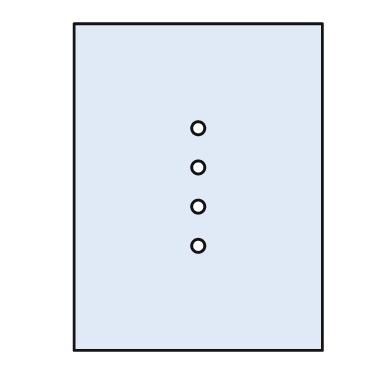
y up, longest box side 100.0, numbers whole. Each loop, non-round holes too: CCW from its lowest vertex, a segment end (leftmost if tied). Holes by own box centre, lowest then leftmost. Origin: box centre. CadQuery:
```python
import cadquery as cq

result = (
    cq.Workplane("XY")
    .moveTo(-38.0, -50.0)
    .lineTo(38.0, -50.0)
    .lineTo(38.0, 50.0)
    .lineTo(-38.0, 50.0)
    .close()
    .moveTo(0.0, -18.0)
    .circle(2.0)
    .moveTo(0.0, -6.0)
    .circle(2.0)
    .moveTo(0.0, 6.0)
    .circle(2.0)
    .moveTo(0.0, 18.0)
    .circle(2.0)
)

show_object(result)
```